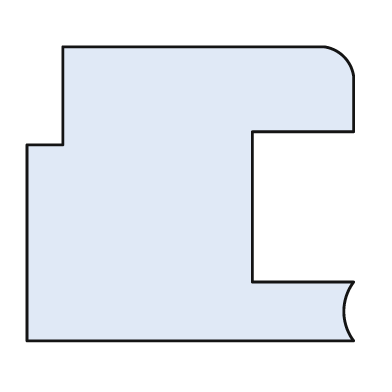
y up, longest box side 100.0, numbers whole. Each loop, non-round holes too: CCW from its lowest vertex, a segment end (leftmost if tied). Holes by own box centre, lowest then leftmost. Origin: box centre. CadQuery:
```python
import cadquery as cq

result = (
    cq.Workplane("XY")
    .moveTo(-50.0, -45.0)
    .lineTo(50.0, -45.0)
    .threePointArc((47.0, -36.0), (50.0, -27.0))
    .lineTo(19.0, -27.0)
    .lineTo(19.0, 19.0)
    .lineTo(50.0, 19.0)
    .lineTo(50.0, 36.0)
    .threePointArc((47.0, 42.0), (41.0, 45.0))
    .lineTo(-39.0, 45.0)
    .lineTo(-39.0, 15.0)
    .lineTo(-50.0, 15.0)
    .close()
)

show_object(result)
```